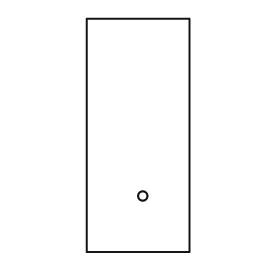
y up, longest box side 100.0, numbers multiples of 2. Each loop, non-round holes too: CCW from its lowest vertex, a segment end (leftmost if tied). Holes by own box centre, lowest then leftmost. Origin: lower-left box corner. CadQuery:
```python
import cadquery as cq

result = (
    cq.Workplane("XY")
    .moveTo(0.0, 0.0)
    .lineTo(44.0, 0.0)
    .lineTo(44.0, 100.0)
    .lineTo(0.0, 100.0)
    .close()
    .moveTo(24.0, 24.0)
    .circle(2.0)
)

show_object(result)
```